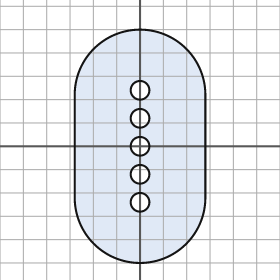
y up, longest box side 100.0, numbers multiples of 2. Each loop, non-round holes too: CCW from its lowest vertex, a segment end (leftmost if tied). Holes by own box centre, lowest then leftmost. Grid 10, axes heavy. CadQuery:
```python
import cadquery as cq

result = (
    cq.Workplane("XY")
    .moveTo(-28.0, -22.0)
    .threePointArc((0.0, -50.0), (28.0, -22.0))
    .lineTo(28.0, 22.0)
    .threePointArc((0.0, 50.0), (-28.0, 22.0))
    .close()
    .moveTo(0.0, -24.0)
    .circle(4.0)
    .moveTo(0.0, -12.0)
    .circle(4.0)
    .moveTo(0.0, 0.0)
    .circle(4.0)
    .moveTo(0.0, 12.0)
    .circle(4.0)
    .moveTo(0.0, 24.0)
    .circle(4.0)
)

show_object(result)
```